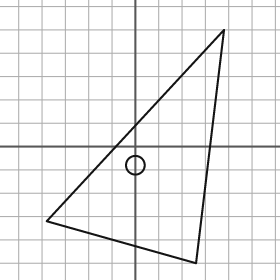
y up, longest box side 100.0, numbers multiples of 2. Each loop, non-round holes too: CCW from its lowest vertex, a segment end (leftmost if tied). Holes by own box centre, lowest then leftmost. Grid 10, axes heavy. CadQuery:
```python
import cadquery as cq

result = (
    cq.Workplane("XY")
    .moveTo(26.0, -50.0)
    .lineTo(38.0, 50.0)
    .lineTo(-38.0, -32.0)
    .close()
    .moveTo(0.0, -8.0)
    .circle(4.0)
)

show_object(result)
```